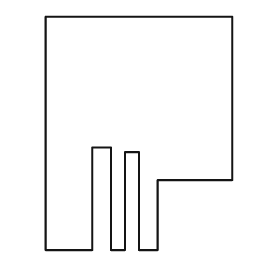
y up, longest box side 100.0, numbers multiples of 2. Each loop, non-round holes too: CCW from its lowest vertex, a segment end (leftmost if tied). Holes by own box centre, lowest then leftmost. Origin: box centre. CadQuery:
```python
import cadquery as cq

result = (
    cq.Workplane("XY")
    .moveTo(-40.0, -50.0)
    .lineTo(-20.0, -50.0)
    .lineTo(-20.0, -6.0)
    .lineTo(-12.0, -6.0)
    .lineTo(-12.0, -50.0)
    .lineTo(-6.0, -50.0)
    .lineTo(-6.0, -8.0)
    .lineTo(0.0, -8.0)
    .lineTo(0.0, -50.0)
    .lineTo(8.0, -50.0)
    .lineTo(8.0, -20.0)
    .lineTo(40.0, -20.0)
    .lineTo(40.0, 50.0)
    .lineTo(-40.0, 50.0)
    .close()
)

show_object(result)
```